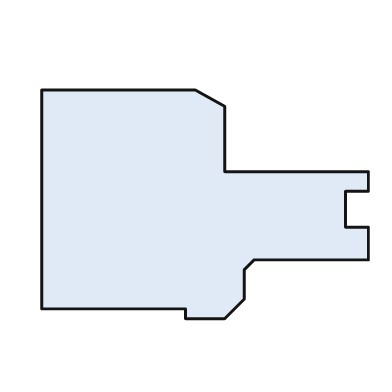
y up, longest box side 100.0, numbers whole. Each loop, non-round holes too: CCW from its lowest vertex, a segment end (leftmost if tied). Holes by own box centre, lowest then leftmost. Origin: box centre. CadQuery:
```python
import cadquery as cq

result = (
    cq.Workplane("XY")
    .moveTo(-6.0, -35.0)
    .lineTo(6.0, -35.0)
    .lineTo(12.0, -29.0)
    .lineTo(12.0, -20.0)
    .lineTo(15.0, -17.0)
    .lineTo(50.0, -17.0)
    .lineTo(50.0, -7.0)
    .lineTo(43.0, -7.0)
    .lineTo(43.0, 4.0)
    .lineTo(50.0, 4.0)
    .lineTo(50.0, 10.0)
    .lineTo(6.0, 10.0)
    .lineTo(6.0, 30.0)
    .lineTo(-3.0, 35.0)
    .lineTo(-50.0, 35.0)
    .lineTo(-50.0, -32.0)
    .lineTo(-6.0, -32.0)
    .close()
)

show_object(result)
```